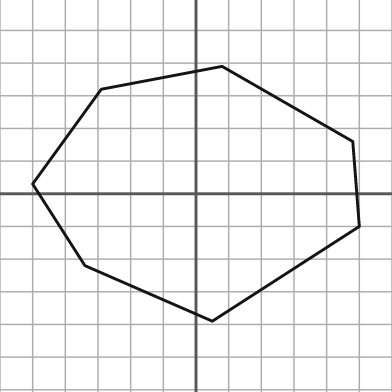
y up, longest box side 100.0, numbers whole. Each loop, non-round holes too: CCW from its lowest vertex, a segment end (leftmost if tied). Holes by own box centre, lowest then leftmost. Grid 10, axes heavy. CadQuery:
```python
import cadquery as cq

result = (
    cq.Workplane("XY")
    .moveTo(5.0, -39.0)
    .lineTo(50.0, -10.0)
    .lineTo(48.0, 16.0)
    .lineTo(8.0, 39.0)
    .lineTo(-29.0, 32.0)
    .lineTo(-50.0, 3.0)
    .lineTo(-34.0, -22.0)
    .close()
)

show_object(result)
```